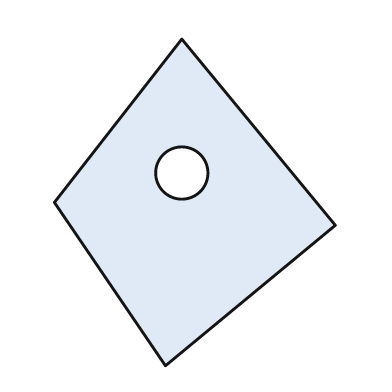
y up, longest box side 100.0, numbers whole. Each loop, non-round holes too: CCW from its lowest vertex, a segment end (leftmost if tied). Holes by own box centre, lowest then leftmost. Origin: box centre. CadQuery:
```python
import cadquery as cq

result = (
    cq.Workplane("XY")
    .moveTo(-9.0, -50.0)
    .lineTo(43.0, -7.0)
    .lineTo(-4.0, 50.0)
    .lineTo(-43.0, 0.0)
    .close()
    .moveTo(-4.0, 9.0)
    .circle(8.0)
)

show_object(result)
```